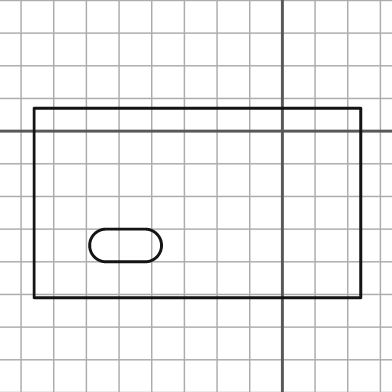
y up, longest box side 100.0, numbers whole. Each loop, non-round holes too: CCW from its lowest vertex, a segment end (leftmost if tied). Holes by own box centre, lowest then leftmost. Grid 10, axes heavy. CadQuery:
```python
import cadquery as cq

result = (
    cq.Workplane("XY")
    .moveTo(-76.0, -51.0)
    .lineTo(24.0, -51.0)
    .lineTo(24.0, 7.0)
    .lineTo(-76.0, 7.0)
    .close()
    .moveTo(-54.0, -40.0)
    .lineTo(-42.0, -40.0)
    .threePointArc((-37.0, -35.0), (-42.0, -30.0))
    .lineTo(-54.0, -30.0)
    .threePointArc((-59.0, -35.0), (-54.0, -40.0))
    .close()
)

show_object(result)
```